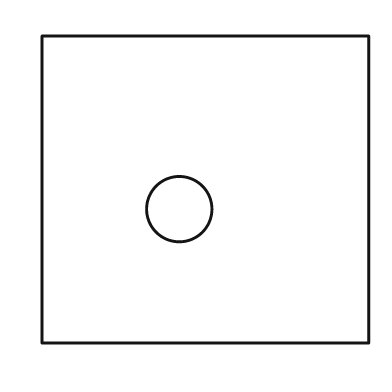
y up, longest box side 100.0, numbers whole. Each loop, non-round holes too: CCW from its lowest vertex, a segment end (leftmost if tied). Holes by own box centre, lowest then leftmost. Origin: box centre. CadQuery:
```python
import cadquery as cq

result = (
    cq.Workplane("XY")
    .moveTo(-50.0, -47.0)
    .lineTo(50.0, -47.0)
    .lineTo(50.0, 47.0)
    .lineTo(-50.0, 47.0)
    .close()
    .moveTo(-8.0, -6.0)
    .circle(10.0)
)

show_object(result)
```